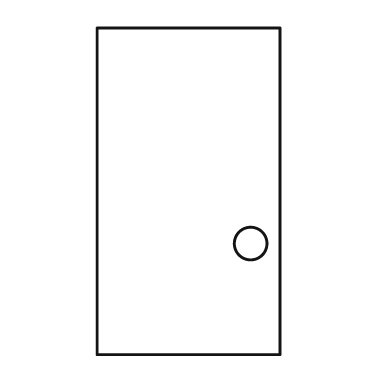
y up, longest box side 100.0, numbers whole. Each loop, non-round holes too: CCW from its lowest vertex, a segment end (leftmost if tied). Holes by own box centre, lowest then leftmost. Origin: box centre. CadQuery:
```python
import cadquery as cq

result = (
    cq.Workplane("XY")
    .moveTo(-28.0, -50.0)
    .lineTo(28.0, -50.0)
    .lineTo(28.0, 50.0)
    .lineTo(-28.0, 50.0)
    .close()
    .moveTo(19.0, -16.0)
    .circle(5.0)
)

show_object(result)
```